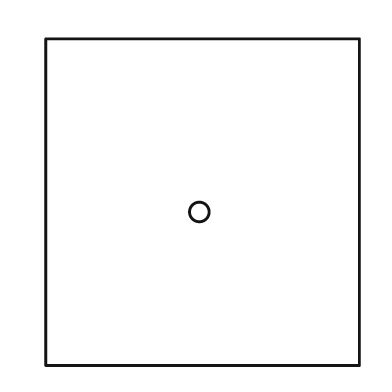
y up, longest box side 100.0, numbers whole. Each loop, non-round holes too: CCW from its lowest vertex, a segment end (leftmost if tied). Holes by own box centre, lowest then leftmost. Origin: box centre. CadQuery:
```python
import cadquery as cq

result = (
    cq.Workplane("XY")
    .moveTo(-48.0, -50.0)
    .lineTo(48.0, -50.0)
    .lineTo(48.0, 50.0)
    .lineTo(-48.0, 50.0)
    .close()
    .moveTo(-1.0, -3.0)
    .circle(3.0)
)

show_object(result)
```